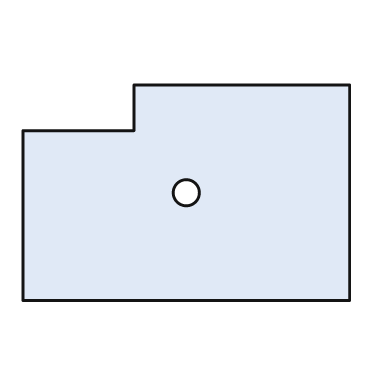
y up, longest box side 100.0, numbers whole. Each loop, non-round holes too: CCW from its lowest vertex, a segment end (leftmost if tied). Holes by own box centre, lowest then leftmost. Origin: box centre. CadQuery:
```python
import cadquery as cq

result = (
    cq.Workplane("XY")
    .moveTo(-50.0, -33.0)
    .lineTo(50.0, -33.0)
    .lineTo(50.0, 33.0)
    .lineTo(-16.0, 33.0)
    .lineTo(-16.0, 19.0)
    .lineTo(-50.0, 19.0)
    .close()
    .moveTo(0.0, 0.0)
    .circle(4.0)
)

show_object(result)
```